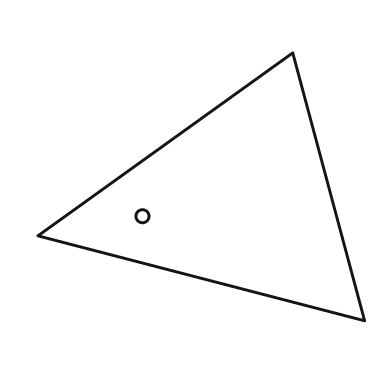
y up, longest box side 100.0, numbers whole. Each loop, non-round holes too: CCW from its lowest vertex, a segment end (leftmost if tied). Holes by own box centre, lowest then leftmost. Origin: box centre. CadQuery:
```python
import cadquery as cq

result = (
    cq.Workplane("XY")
    .moveTo(50.0, -41.0)
    .lineTo(28.0, 41.0)
    .lineTo(-50.0, -15.0)
    .close()
    .moveTo(-18.0, -9.0)
    .circle(2.0)
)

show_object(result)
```